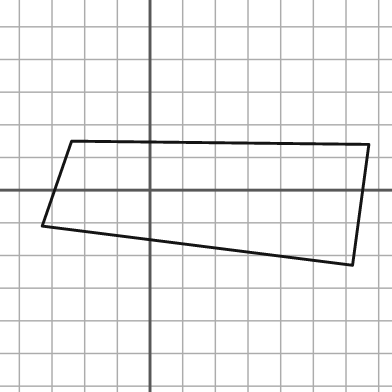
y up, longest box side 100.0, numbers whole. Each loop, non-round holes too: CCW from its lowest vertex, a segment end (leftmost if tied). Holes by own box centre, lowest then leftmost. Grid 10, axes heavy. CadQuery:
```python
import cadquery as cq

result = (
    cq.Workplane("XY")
    .moveTo(62.0, -23.0)
    .lineTo(67.0, 14.0)
    .lineTo(-24.0, 15.0)
    .lineTo(-33.0, -11.0)
    .close()
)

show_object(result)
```